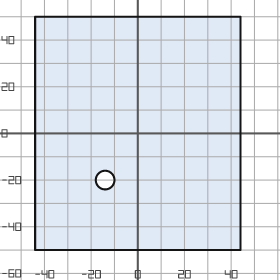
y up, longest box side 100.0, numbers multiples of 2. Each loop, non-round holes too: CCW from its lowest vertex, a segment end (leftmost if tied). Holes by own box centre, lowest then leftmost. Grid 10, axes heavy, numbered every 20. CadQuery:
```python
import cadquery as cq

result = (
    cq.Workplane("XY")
    .moveTo(-44.0, -50.0)
    .lineTo(44.0, -50.0)
    .lineTo(44.0, 50.0)
    .lineTo(-44.0, 50.0)
    .close()
    .moveTo(-14.0, -20.0)
    .circle(4.0)
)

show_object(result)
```